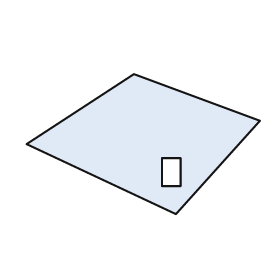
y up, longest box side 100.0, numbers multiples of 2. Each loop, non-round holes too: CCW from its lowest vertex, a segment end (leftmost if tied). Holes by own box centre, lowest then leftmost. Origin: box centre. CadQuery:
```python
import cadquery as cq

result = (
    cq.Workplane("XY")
    .moveTo(14.0, -30.0)
    .lineTo(50.0, 10.0)
    .lineTo(-4.0, 30.0)
    .lineTo(-50.0, 0.0)
    .close()
    .moveTo(8.0, -18.0)
    .lineTo(16.0, -18.0)
    .lineTo(16.0, -6.0)
    .lineTo(8.0, -6.0)
    .close()
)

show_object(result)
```